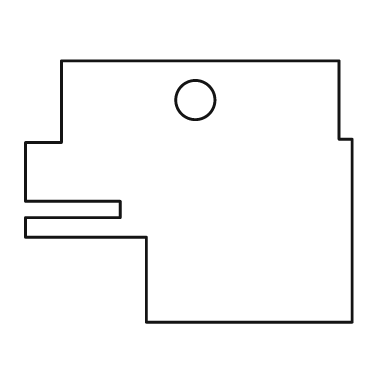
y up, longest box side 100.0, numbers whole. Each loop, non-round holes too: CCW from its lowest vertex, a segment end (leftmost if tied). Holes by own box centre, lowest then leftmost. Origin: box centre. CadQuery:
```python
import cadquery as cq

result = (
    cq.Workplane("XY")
    .moveTo(-13.0, -40.0)
    .lineTo(50.0, -40.0)
    .lineTo(50.0, 16.0)
    .lineTo(46.0, 16.0)
    .lineTo(46.0, 40.0)
    .lineTo(-39.0, 40.0)
    .lineTo(-39.0, 15.0)
    .lineTo(-50.0, 15.0)
    .lineTo(-50.0, -3.0)
    .lineTo(-21.0, -3.0)
    .lineTo(-21.0, -8.0)
    .lineTo(-50.0, -8.0)
    .lineTo(-50.0, -14.0)
    .lineTo(-13.0, -14.0)
    .close()
    .moveTo(2.0, 28.0)
    .circle(6.0)
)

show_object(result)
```